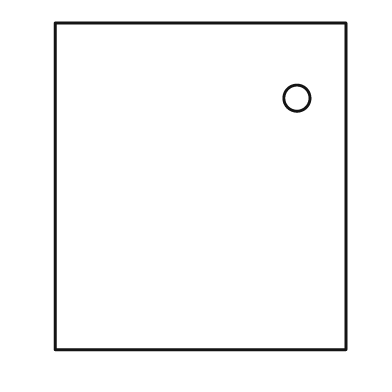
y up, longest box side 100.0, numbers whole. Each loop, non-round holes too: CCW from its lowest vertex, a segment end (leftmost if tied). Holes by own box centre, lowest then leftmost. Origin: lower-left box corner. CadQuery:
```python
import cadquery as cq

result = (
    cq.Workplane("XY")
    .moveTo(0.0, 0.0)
    .lineTo(89.0, 0.0)
    .lineTo(89.0, 100.0)
    .lineTo(0.0, 100.0)
    .close()
    .moveTo(74.0, 77.0)
    .circle(4.0)
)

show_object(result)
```